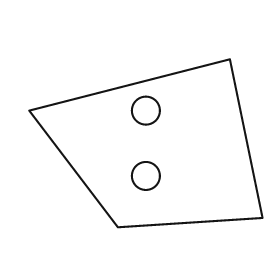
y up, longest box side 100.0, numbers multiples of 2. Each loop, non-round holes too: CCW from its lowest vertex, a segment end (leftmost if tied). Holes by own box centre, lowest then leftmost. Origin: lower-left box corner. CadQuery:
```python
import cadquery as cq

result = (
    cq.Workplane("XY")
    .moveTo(38.0, 0.0)
    .lineTo(100.0, 4.0)
    .lineTo(86.0, 72.0)
    .lineTo(0.0, 50.0)
    .close()
    .moveTo(50.0, 22.0)
    .circle(6.0)
    .moveTo(50.0, 50.0)
    .circle(6.0)
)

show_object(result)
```